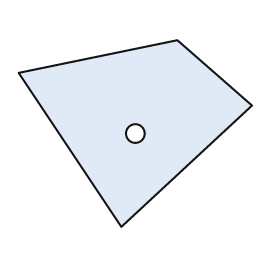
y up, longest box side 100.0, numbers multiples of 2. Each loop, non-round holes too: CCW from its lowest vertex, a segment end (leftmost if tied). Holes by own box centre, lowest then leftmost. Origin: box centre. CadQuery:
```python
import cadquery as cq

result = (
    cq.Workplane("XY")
    .moveTo(-6.0, -40.0)
    .lineTo(50.0, 12.0)
    .lineTo(18.0, 40.0)
    .lineTo(-50.0, 26.0)
    .close()
    .moveTo(0.0, 0.0)
    .circle(4.0)
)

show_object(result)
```